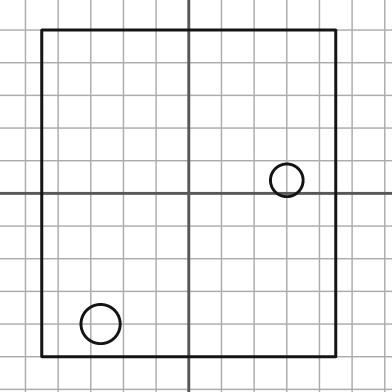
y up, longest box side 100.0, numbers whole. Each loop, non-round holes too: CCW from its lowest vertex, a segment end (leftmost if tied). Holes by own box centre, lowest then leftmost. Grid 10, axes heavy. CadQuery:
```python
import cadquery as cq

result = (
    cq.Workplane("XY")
    .moveTo(-45.0, -50.0)
    .lineTo(45.0, -50.0)
    .lineTo(45.0, 50.0)
    .lineTo(-45.0, 50.0)
    .close()
    .moveTo(-27.0, -40.0)
    .circle(6.0)
    .moveTo(30.0, 4.0)
    .circle(5.0)
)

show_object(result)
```